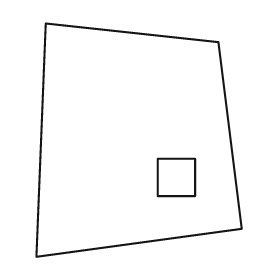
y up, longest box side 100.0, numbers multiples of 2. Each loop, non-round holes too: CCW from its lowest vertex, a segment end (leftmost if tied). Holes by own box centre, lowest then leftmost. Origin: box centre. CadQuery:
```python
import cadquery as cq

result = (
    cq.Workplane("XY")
    .moveTo(-44.0, -50.0)
    .lineTo(44.0, -38.0)
    .lineTo(34.0, 42.0)
    .lineTo(-40.0, 50.0)
    .close()
    .moveTo(8.0, -24.0)
    .lineTo(24.0, -24.0)
    .lineTo(24.0, -8.0)
    .lineTo(8.0, -8.0)
    .close()
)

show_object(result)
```